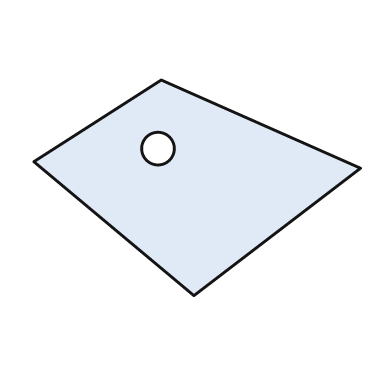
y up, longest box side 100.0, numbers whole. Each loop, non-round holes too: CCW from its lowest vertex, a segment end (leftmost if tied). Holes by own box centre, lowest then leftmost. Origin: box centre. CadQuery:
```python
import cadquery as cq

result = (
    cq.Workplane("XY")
    .moveTo(-1.0, -33.0)
    .lineTo(50.0, 6.0)
    .lineTo(-11.0, 33.0)
    .lineTo(-50.0, 8.0)
    .close()
    .moveTo(-12.0, 12.0)
    .circle(5.0)
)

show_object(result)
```